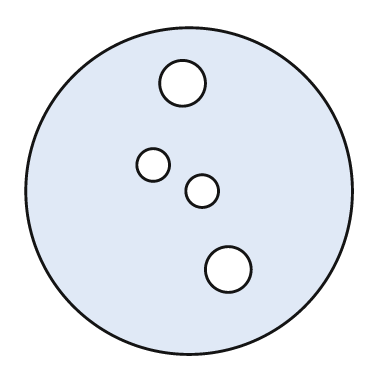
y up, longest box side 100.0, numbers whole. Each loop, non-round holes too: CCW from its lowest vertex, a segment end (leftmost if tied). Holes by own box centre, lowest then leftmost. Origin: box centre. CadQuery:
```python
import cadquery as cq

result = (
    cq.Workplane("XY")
    .moveTo(0.0, 0.0)
    .circle(50.0)
    .moveTo(12.0, -24.0)
    .circle(7.0)
    .moveTo(4.0, 0.0)
    .circle(5.0)
    .moveTo(-11.0, 8.0)
    .circle(5.0)
    .moveTo(-2.0, 33.0)
    .circle(7.0)
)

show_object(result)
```